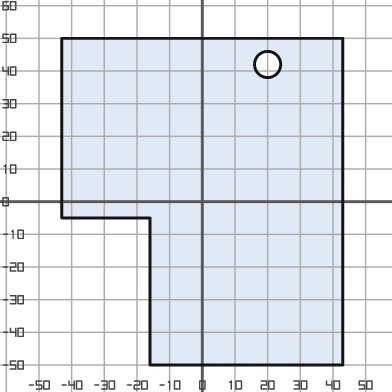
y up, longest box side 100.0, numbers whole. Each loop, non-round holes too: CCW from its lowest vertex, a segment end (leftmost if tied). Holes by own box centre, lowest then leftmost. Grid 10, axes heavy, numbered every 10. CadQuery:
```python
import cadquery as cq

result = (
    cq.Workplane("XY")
    .moveTo(-16.0, -50.0)
    .lineTo(43.0, -50.0)
    .lineTo(43.0, 50.0)
    .lineTo(-43.0, 50.0)
    .lineTo(-43.0, -5.0)
    .lineTo(-16.0, -5.0)
    .close()
    .moveTo(20.0, 42.0)
    .circle(4.0)
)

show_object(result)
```